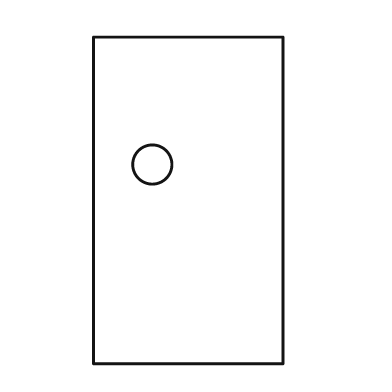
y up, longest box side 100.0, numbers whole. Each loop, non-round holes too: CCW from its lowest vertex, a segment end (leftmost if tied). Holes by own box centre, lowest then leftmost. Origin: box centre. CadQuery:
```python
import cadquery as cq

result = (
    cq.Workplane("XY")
    .moveTo(-29.0, -50.0)
    .lineTo(29.0, -50.0)
    .lineTo(29.0, 50.0)
    .lineTo(-29.0, 50.0)
    .close()
    .moveTo(-11.0, 11.0)
    .circle(6.0)
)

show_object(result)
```